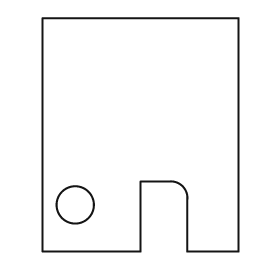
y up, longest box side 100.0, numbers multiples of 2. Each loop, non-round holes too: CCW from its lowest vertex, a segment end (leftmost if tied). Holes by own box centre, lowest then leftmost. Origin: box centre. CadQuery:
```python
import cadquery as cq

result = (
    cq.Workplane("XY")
    .moveTo(-42.0, -50.0)
    .lineTo(0.0, -50.0)
    .lineTo(0.0, -20.0)
    .lineTo(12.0, -20.0)
    .threePointArc((18.0, -22.0), (20.0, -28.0))
    .lineTo(20.0, -50.0)
    .lineTo(42.0, -50.0)
    .lineTo(42.0, 50.0)
    .lineTo(-42.0, 50.0)
    .close()
    .moveTo(-28.0, -30.0)
    .circle(8.0)
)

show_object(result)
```